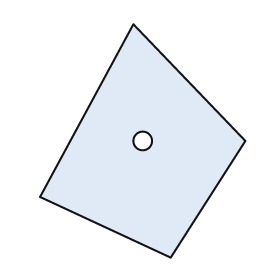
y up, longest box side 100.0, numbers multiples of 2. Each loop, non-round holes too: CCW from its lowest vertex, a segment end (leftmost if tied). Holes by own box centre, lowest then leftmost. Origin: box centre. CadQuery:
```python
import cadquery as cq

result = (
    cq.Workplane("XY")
    .moveTo(12.0, -50.0)
    .lineTo(44.0, 0.0)
    .lineTo(-4.0, 50.0)
    .lineTo(-44.0, -24.0)
    .close()
    .moveTo(0.0, 0.0)
    .circle(4.0)
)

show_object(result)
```